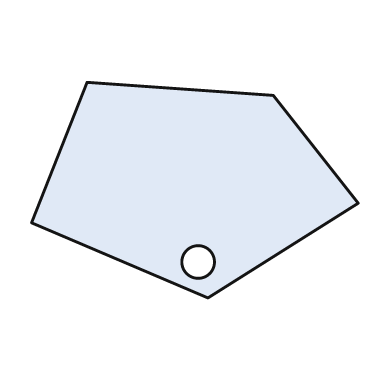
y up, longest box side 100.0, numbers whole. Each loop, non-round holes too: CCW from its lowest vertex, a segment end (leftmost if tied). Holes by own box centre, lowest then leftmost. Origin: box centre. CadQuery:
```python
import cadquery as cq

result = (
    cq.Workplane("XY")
    .moveTo(4.0, -33.0)
    .lineTo(50.0, -4.0)
    .lineTo(24.0, 29.0)
    .lineTo(-33.0, 33.0)
    .lineTo(-50.0, -10.0)
    .close()
    .moveTo(1.0, -22.0)
    .circle(5.0)
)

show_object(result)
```